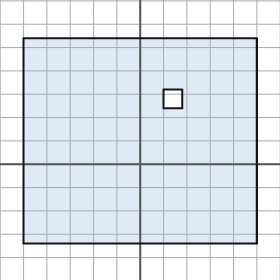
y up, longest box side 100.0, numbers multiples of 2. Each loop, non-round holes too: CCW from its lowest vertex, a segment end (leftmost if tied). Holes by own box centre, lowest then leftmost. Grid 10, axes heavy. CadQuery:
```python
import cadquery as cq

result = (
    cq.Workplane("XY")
    .moveTo(-50.0, -34.0)
    .lineTo(50.0, -34.0)
    .lineTo(50.0, 54.0)
    .lineTo(-50.0, 54.0)
    .close()
    .moveTo(10.0, 24.0)
    .lineTo(18.0, 24.0)
    .lineTo(18.0, 32.0)
    .lineTo(10.0, 32.0)
    .close()
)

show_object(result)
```